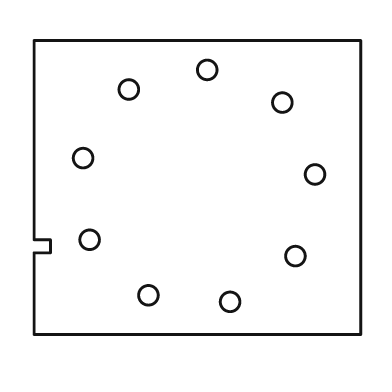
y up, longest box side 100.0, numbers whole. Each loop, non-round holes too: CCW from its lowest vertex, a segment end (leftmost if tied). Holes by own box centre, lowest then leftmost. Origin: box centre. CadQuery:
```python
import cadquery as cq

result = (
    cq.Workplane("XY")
    .moveTo(-50.0, -45.0)
    .lineTo(50.0, -45.0)
    .lineTo(50.0, 45.0)
    .lineTo(-50.0, 45.0)
    .lineTo(-50.0, -16.0)
    .lineTo(-45.0, -16.0)
    .lineTo(-45.0, -20.0)
    .lineTo(-50.0, -20.0)
    .close()
    .moveTo(10.0, -35.0)
    .circle(3.0)
    .moveTo(-15.0, -33.0)
    .circle(3.0)
    .moveTo(30.0, -21.0)
    .circle(3.0)
    .moveTo(-33.0, -16.0)
    .circle(3.0)
    .moveTo(36.0, 4.0)
    .circle(3.0)
    .moveTo(-35.0, 9.0)
    .circle(3.0)
    .moveTo(26.0, 26.0)
    .circle(3.0)
    .moveTo(-21.0, 30.0)
    .circle(3.0)
    .moveTo(3.0, 36.0)
    .circle(3.0)
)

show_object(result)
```